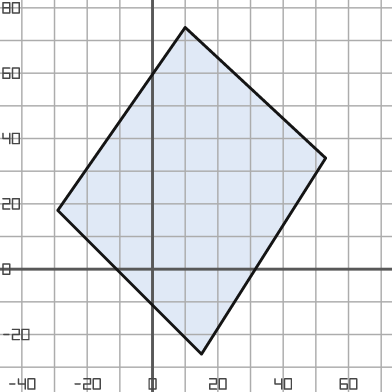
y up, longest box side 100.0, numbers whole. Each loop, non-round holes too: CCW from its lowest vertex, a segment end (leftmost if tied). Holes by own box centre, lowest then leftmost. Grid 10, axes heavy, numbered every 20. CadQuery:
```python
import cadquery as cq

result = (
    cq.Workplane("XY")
    .moveTo(15.0, -26.0)
    .lineTo(53.0, 34.0)
    .lineTo(10.0, 74.0)
    .lineTo(-29.0, 18.0)
    .close()
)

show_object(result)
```